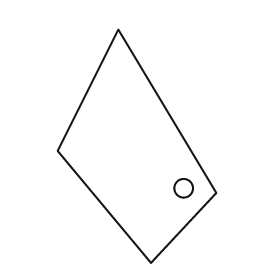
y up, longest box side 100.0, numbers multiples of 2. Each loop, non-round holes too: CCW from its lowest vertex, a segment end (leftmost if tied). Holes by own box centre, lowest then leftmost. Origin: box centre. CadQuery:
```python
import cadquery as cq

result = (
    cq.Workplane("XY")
    .moveTo(6.0, -50.0)
    .lineTo(34.0, -20.0)
    .lineTo(-8.0, 50.0)
    .lineTo(-34.0, -2.0)
    .close()
    .moveTo(20.0, -18.0)
    .circle(4.0)
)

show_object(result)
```